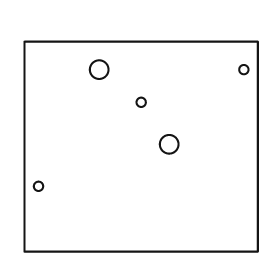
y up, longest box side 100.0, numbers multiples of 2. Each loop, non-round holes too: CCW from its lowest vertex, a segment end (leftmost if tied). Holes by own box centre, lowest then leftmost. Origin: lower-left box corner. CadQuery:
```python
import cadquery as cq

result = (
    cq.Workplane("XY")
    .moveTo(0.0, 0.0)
    .lineTo(100.0, 0.0)
    .lineTo(100.0, 90.0)
    .lineTo(0.0, 90.0)
    .close()
    .moveTo(6.0, 28.0)
    .circle(2.0)
    .moveTo(62.0, 46.0)
    .circle(4.0)
    .moveTo(50.0, 64.0)
    .circle(2.0)
    .moveTo(32.0, 78.0)
    .circle(4.0)
    .moveTo(94.0, 78.0)
    .circle(2.0)
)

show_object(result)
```